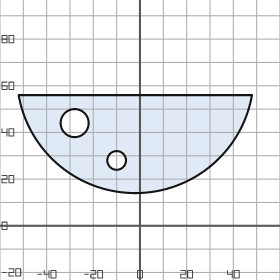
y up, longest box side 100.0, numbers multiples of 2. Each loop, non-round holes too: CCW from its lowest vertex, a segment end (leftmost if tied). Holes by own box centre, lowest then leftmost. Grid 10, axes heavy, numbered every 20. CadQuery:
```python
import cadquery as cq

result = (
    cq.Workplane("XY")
    .moveTo(-52.0, 56.0)
    .threePointArc((-2.0, 14.0), (48.0, 56.0))
    .close()
    .moveTo(-10.0, 28.0)
    .circle(4.0)
    .moveTo(-28.0, 44.0)
    .circle(6.0)
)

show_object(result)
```